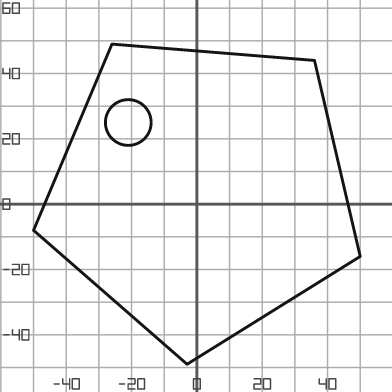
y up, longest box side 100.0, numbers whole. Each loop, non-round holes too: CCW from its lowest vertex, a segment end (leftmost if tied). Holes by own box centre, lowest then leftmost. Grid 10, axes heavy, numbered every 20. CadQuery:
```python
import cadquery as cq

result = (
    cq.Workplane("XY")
    .moveTo(-3.0, -49.0)
    .lineTo(50.0, -16.0)
    .lineTo(36.0, 44.0)
    .lineTo(-26.0, 49.0)
    .lineTo(-50.0, -8.0)
    .close()
    .moveTo(-21.0, 25.0)
    .circle(7.0)
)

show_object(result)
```